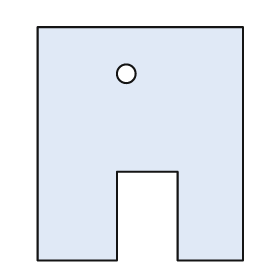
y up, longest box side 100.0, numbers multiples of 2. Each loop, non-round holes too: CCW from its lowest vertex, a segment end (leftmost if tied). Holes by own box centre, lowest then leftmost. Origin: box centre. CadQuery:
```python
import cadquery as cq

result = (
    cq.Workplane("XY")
    .moveTo(-44.0, -50.0)
    .lineTo(-10.0, -50.0)
    .lineTo(-10.0, -12.0)
    .lineTo(16.0, -12.0)
    .lineTo(16.0, -50.0)
    .lineTo(44.0, -50.0)
    .lineTo(44.0, 50.0)
    .lineTo(-44.0, 50.0)
    .close()
    .moveTo(-6.0, 30.0)
    .circle(4.0)
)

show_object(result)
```